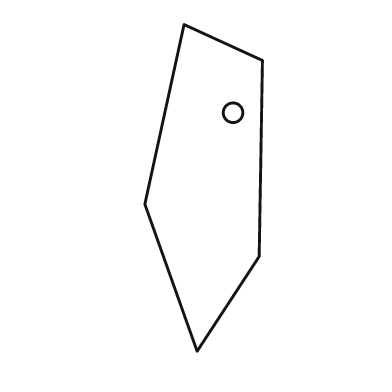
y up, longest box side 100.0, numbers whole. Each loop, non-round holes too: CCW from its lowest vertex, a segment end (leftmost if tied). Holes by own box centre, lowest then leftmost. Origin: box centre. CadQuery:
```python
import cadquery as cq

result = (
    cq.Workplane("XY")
    .moveTo(-2.0, -50.0)
    .lineTo(17.0, -21.0)
    .lineTo(18.0, 39.0)
    .lineTo(-6.0, 50.0)
    .lineTo(-18.0, -5.0)
    .close()
    .moveTo(9.0, 23.0)
    .circle(3.0)
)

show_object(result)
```